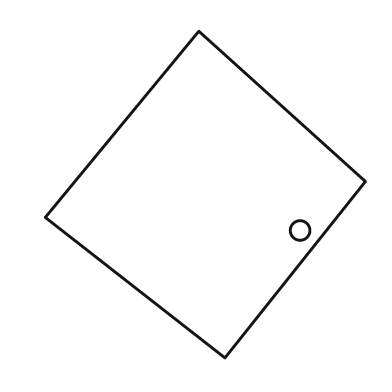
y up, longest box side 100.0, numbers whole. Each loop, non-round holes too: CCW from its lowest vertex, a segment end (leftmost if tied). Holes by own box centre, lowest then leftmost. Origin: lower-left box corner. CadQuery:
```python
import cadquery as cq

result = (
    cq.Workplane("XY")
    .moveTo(55.0, 0.0)
    .lineTo(98.0, 54.0)
    .lineTo(47.0, 100.0)
    .lineTo(0.0, 43.0)
    .close()
    .moveTo(78.0, 39.0)
    .circle(3.0)
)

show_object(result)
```